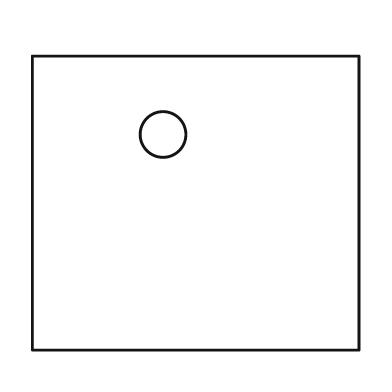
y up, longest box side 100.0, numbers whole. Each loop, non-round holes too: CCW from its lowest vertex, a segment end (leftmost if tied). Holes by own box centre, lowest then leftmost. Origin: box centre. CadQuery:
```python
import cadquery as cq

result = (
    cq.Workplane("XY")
    .moveTo(-50.0, -45.0)
    .lineTo(50.0, -45.0)
    .lineTo(50.0, 45.0)
    .lineTo(-50.0, 45.0)
    .close()
    .moveTo(-10.0, 21.0)
    .circle(7.0)
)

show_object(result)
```